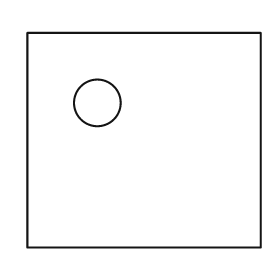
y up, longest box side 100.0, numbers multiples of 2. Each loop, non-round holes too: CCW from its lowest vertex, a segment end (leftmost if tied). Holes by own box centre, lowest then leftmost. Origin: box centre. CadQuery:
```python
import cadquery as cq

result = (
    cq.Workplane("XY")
    .moveTo(-50.0, -46.0)
    .lineTo(50.0, -46.0)
    .lineTo(50.0, 46.0)
    .lineTo(-50.0, 46.0)
    .close()
    .moveTo(-20.0, 16.0)
    .circle(10.0)
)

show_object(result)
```